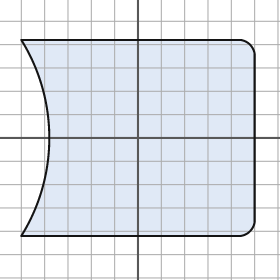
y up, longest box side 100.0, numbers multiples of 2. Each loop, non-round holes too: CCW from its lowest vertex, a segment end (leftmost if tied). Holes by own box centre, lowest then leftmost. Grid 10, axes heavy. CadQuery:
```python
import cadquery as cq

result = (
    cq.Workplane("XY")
    .moveTo(-50.0, -42.0)
    .lineTo(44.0, -42.0)
    .threePointArc((48.0, -40.0), (50.0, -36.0))
    .lineTo(50.0, 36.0)
    .threePointArc((48.0, 40.0), (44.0, 42.0))
    .lineTo(-50.0, 42.0)
    .threePointArc((-38.0, 0.0), (-50.0, -42.0))
    .close()
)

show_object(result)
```